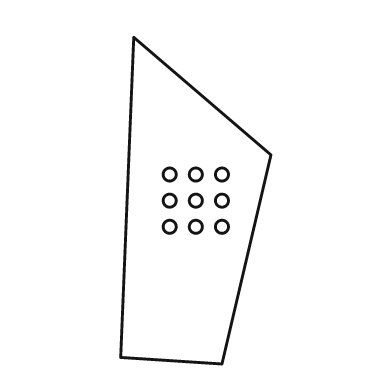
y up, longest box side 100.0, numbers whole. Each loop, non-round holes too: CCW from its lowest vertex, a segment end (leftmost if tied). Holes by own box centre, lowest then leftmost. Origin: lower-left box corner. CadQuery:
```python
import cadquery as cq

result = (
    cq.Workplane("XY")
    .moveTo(31.0, 0.0)
    .lineTo(46.0, 64.0)
    .lineTo(4.0, 100.0)
    .lineTo(0.0, 2.0)
    .close()
    .moveTo(15.0, 42.0)
    .circle(2.0)
    .moveTo(23.0, 42.0)
    .circle(2.0)
    .moveTo(31.0, 42.0)
    .circle(2.0)
    .moveTo(15.0, 50.0)
    .circle(2.0)
    .moveTo(23.0, 50.0)
    .circle(2.0)
    .moveTo(31.0, 50.0)
    .circle(2.0)
    .moveTo(15.0, 58.0)
    .circle(2.0)
    .moveTo(23.0, 58.0)
    .circle(2.0)
    .moveTo(31.0, 58.0)
    .circle(2.0)
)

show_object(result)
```